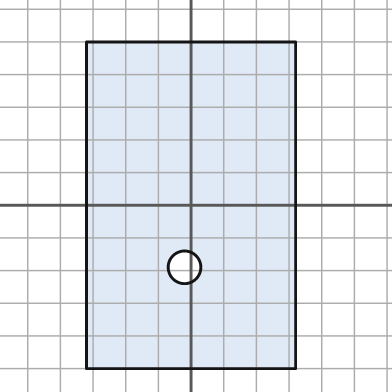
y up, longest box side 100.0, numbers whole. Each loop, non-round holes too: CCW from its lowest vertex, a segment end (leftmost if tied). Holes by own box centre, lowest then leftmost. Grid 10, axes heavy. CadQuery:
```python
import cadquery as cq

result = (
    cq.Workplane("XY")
    .moveTo(-32.0, -50.0)
    .lineTo(32.0, -50.0)
    .lineTo(32.0, 50.0)
    .lineTo(-32.0, 50.0)
    .close()
    .moveTo(-2.0, -19.0)
    .circle(5.0)
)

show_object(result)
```